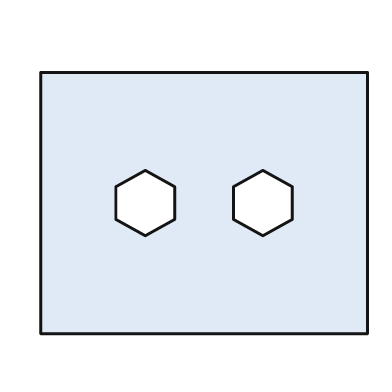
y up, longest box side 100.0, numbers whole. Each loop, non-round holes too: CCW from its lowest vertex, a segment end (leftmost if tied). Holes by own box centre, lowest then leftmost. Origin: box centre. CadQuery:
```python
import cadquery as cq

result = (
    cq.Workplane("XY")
    .moveTo(-50.0, -40.0)
    .lineTo(50.0, -40.0)
    .lineTo(50.0, 40.0)
    .lineTo(-50.0, 40.0)
    .close()
    .moveTo(-18.0, -10.0)
    .lineTo(-9.0, -5.0)
    .lineTo(-9.0, 5.0)
    .lineTo(-18.0, 10.0)
    .lineTo(-27.0, 5.0)
    .lineTo(-27.0, -5.0)
    .close()
    .moveTo(18.0, -10.0)
    .lineTo(27.0, -5.0)
    .lineTo(27.0, 5.0)
    .lineTo(18.0, 10.0)
    .lineTo(9.0, 5.0)
    .lineTo(9.0, -5.0)
    .close()
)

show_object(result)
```